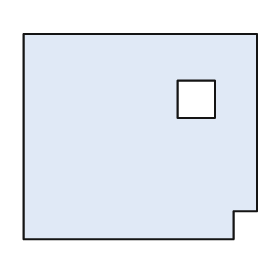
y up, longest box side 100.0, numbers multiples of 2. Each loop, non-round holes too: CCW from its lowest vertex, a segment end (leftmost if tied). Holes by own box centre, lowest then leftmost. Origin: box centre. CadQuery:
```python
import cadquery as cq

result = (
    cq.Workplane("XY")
    .moveTo(-50.0, -44.0)
    .lineTo(40.0, -44.0)
    .lineTo(40.0, -32.0)
    .lineTo(50.0, -32.0)
    .lineTo(50.0, 44.0)
    .lineTo(-50.0, 44.0)
    .close()
    .moveTo(16.0, 8.0)
    .lineTo(32.0, 8.0)
    .lineTo(32.0, 24.0)
    .lineTo(16.0, 24.0)
    .close()
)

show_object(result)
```